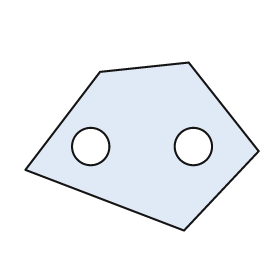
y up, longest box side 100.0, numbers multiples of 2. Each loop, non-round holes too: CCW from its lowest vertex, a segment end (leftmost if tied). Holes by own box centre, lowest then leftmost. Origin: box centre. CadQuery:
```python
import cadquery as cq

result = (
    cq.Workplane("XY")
    .moveTo(18.0, -36.0)
    .lineTo(50.0, -2.0)
    .lineTo(20.0, 36.0)
    .lineTo(-18.0, 32.0)
    .lineTo(-50.0, -10.0)
    .close()
    .moveTo(-22.0, 0.0)
    .circle(8.0)
    .moveTo(22.0, 0.0)
    .circle(8.0)
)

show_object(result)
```